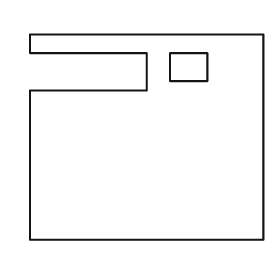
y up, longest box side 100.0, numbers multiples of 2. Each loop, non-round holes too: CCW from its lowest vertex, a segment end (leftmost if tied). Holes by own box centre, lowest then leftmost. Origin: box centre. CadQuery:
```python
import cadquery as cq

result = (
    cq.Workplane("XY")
    .moveTo(-50.0, -44.0)
    .lineTo(50.0, -44.0)
    .lineTo(50.0, 44.0)
    .lineTo(-50.0, 44.0)
    .lineTo(-50.0, 36.0)
    .lineTo(0.0, 36.0)
    .lineTo(0.0, 20.0)
    .lineTo(-50.0, 20.0)
    .close()
    .moveTo(10.0, 24.0)
    .lineTo(26.0, 24.0)
    .lineTo(26.0, 36.0)
    .lineTo(10.0, 36.0)
    .close()
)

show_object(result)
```